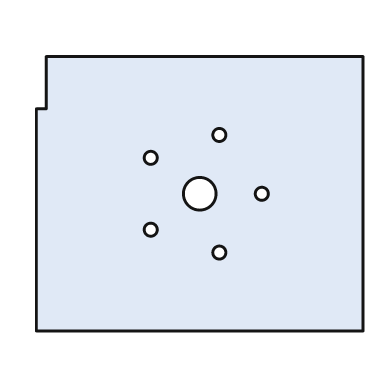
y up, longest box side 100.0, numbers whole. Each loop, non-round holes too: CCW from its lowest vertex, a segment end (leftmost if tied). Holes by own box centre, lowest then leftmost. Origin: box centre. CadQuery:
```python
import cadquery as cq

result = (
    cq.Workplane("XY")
    .moveTo(-50.0, -42.0)
    .lineTo(50.0, -42.0)
    .lineTo(50.0, 42.0)
    .lineTo(-47.0, 42.0)
    .lineTo(-47.0, 26.0)
    .lineTo(-50.0, 26.0)
    .close()
    .moveTo(6.0, -18.0)
    .circle(2.0)
    .moveTo(-15.0, -11.0)
    .circle(2.0)
    .moveTo(0.0, 0.0)
    .circle(5.0)
    .moveTo(19.0, 0.0)
    .circle(2.0)
    .moveTo(-15.0, 11.0)
    .circle(2.0)
    .moveTo(6.0, 18.0)
    .circle(2.0)
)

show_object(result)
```